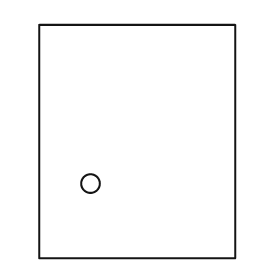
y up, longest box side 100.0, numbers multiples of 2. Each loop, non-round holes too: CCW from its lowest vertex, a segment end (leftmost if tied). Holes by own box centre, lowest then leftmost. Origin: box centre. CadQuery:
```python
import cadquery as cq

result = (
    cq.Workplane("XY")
    .moveTo(-42.0, -50.0)
    .lineTo(42.0, -50.0)
    .lineTo(42.0, 50.0)
    .lineTo(-42.0, 50.0)
    .close()
    .moveTo(-20.0, -18.0)
    .circle(4.0)
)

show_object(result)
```